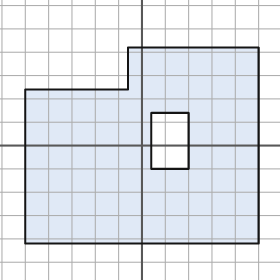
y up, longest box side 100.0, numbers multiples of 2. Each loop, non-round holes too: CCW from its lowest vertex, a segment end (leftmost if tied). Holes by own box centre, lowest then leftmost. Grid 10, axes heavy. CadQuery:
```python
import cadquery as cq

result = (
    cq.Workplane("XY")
    .moveTo(-50.0, -42.0)
    .lineTo(50.0, -42.0)
    .lineTo(50.0, 42.0)
    .lineTo(-6.0, 42.0)
    .lineTo(-6.0, 24.0)
    .lineTo(-50.0, 24.0)
    .close()
    .moveTo(4.0, -10.0)
    .lineTo(20.0, -10.0)
    .lineTo(20.0, 14.0)
    .lineTo(4.0, 14.0)
    .close()
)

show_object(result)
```